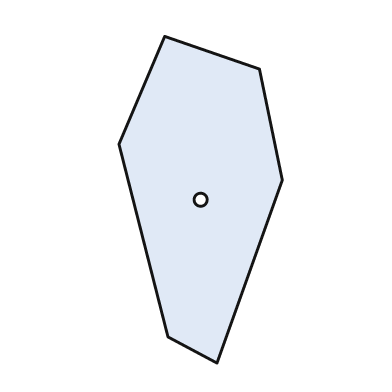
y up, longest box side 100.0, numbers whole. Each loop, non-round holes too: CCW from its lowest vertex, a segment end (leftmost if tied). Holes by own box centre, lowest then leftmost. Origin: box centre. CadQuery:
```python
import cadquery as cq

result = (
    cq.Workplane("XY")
    .moveTo(5.0, -50.0)
    .lineTo(25.0, 6.0)
    .lineTo(18.0, 40.0)
    .lineTo(-11.0, 50.0)
    .lineTo(-25.0, 17.0)
    .lineTo(-10.0, -42.0)
    .close()
    .moveTo(0.0, 0.0)
    .circle(2.0)
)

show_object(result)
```